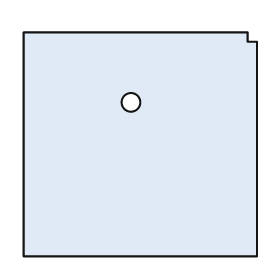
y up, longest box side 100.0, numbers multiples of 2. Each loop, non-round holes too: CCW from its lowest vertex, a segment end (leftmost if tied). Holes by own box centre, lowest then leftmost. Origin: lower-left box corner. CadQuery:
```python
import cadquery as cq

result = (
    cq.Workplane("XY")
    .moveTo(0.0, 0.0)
    .lineTo(100.0, 0.0)
    .lineTo(100.0, 92.0)
    .lineTo(96.0, 92.0)
    .lineTo(96.0, 96.0)
    .lineTo(0.0, 96.0)
    .close()
    .moveTo(46.0, 66.0)
    .circle(4.0)
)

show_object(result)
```